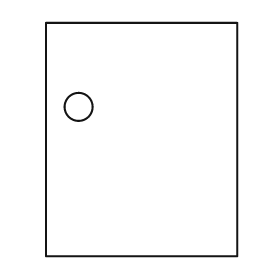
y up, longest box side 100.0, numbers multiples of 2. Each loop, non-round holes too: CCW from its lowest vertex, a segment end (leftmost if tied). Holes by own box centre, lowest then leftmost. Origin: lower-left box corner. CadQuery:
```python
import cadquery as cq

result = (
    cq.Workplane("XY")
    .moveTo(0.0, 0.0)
    .lineTo(82.0, 0.0)
    .lineTo(82.0, 100.0)
    .lineTo(0.0, 100.0)
    .close()
    .moveTo(14.0, 64.0)
    .circle(6.0)
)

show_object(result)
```